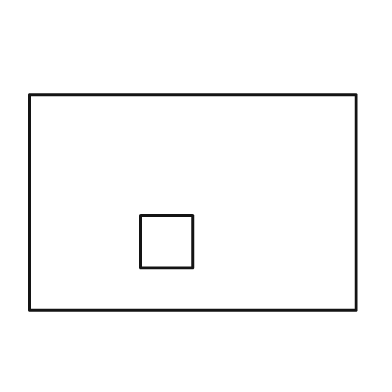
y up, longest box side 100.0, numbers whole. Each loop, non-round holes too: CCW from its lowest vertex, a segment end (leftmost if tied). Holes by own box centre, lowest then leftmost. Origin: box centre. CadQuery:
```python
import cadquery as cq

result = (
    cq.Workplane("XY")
    .moveTo(-50.0, -33.0)
    .lineTo(50.0, -33.0)
    .lineTo(50.0, 33.0)
    .lineTo(-50.0, 33.0)
    .close()
    .moveTo(-16.0, -20.0)
    .lineTo(0.0, -20.0)
    .lineTo(0.0, -4.0)
    .lineTo(-16.0, -4.0)
    .close()
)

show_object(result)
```